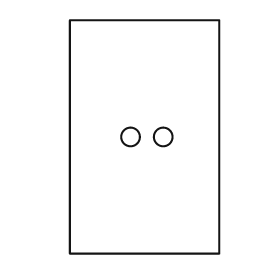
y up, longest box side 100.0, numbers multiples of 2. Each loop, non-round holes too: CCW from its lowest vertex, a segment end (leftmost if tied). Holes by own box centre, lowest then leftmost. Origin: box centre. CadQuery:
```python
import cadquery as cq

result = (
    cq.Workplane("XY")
    .moveTo(-32.0, -50.0)
    .lineTo(32.0, -50.0)
    .lineTo(32.0, 50.0)
    .lineTo(-32.0, 50.0)
    .close()
    .moveTo(-6.0, 0.0)
    .circle(4.0)
    .moveTo(8.0, 0.0)
    .circle(4.0)
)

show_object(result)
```